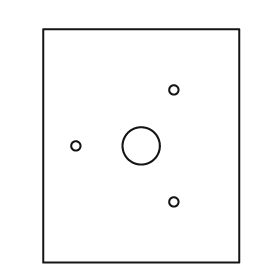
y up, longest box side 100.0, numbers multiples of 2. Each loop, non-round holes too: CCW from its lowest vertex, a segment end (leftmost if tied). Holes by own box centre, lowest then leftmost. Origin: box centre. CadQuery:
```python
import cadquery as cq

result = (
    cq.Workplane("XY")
    .moveTo(-42.0, -50.0)
    .lineTo(42.0, -50.0)
    .lineTo(42.0, 50.0)
    .lineTo(-42.0, 50.0)
    .close()
    .moveTo(14.0, -24.0)
    .circle(2.0)
    .moveTo(-28.0, 0.0)
    .circle(2.0)
    .moveTo(0.0, 0.0)
    .circle(8.0)
    .moveTo(14.0, 24.0)
    .circle(2.0)
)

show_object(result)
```